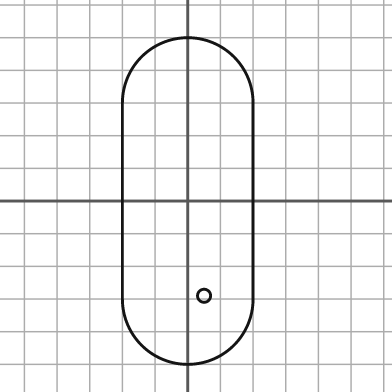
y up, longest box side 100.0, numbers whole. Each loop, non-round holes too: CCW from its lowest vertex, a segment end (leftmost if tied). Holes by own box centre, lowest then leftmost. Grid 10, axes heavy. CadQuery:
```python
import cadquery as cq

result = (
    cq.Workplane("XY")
    .moveTo(-20.0, -30.0)
    .threePointArc((0.0, -50.0), (20.0, -30.0))
    .lineTo(20.0, 30.0)
    .threePointArc((0.0, 50.0), (-20.0, 30.0))
    .close()
    .moveTo(5.0, -29.0)
    .circle(2.0)
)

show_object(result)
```